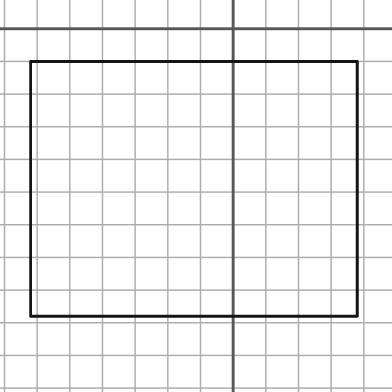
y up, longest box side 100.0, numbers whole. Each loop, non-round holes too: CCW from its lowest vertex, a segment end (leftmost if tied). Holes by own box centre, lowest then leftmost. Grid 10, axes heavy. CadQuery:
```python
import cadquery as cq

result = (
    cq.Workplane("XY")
    .moveTo(-62.0, -88.0)
    .lineTo(38.0, -88.0)
    .lineTo(38.0, -10.0)
    .lineTo(-62.0, -10.0)
    .close()
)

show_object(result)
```